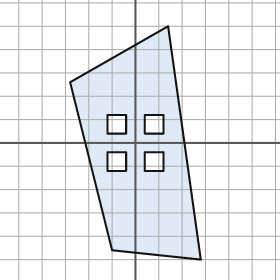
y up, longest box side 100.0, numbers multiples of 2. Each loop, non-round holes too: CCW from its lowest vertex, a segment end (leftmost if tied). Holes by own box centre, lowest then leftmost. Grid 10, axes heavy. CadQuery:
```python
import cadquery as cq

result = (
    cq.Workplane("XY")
    .moveTo(28.0, -50.0)
    .lineTo(14.0, 50.0)
    .lineTo(-28.0, 26.0)
    .lineTo(-10.0, -46.0)
    .close()
    .moveTo(-12.0, -12.0)
    .lineTo(-4.0, -12.0)
    .lineTo(-4.0, -4.0)
    .lineTo(-12.0, -4.0)
    .close()
    .moveTo(4.0, -12.0)
    .lineTo(12.0, -12.0)
    .lineTo(12.0, -4.0)
    .lineTo(4.0, -4.0)
    .close()
    .moveTo(-12.0, 4.0)
    .lineTo(-4.0, 4.0)
    .lineTo(-4.0, 12.0)
    .lineTo(-12.0, 12.0)
    .close()
    .moveTo(4.0, 4.0)
    .lineTo(12.0, 4.0)
    .lineTo(12.0, 12.0)
    .lineTo(4.0, 12.0)
    .close()
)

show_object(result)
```